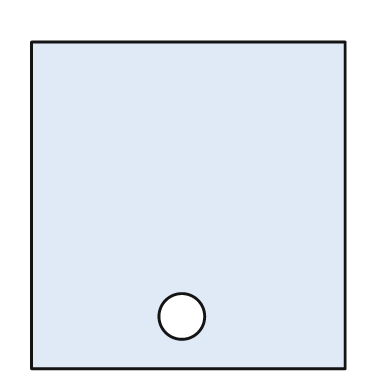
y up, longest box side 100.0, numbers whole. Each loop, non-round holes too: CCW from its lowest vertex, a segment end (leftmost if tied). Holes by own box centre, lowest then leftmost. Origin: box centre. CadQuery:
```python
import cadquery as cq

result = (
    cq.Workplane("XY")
    .moveTo(-48.0, -50.0)
    .lineTo(48.0, -50.0)
    .lineTo(48.0, 50.0)
    .lineTo(-48.0, 50.0)
    .close()
    .moveTo(-2.0, -34.0)
    .circle(7.0)
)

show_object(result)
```